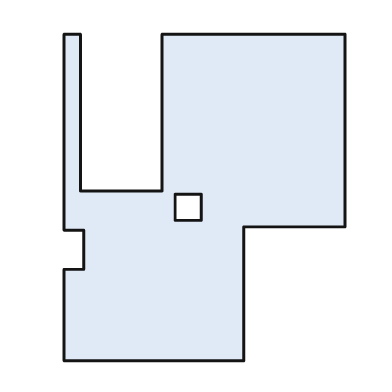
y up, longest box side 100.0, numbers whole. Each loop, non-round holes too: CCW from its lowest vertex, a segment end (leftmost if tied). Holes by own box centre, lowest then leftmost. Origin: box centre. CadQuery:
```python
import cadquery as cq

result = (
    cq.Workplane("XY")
    .moveTo(-43.0, -50.0)
    .lineTo(12.0, -50.0)
    .lineTo(12.0, -9.0)
    .lineTo(43.0, -9.0)
    .lineTo(43.0, 50.0)
    .lineTo(-13.0, 50.0)
    .lineTo(-13.0, 2.0)
    .lineTo(-38.0, 2.0)
    .lineTo(-38.0, 50.0)
    .lineTo(-43.0, 50.0)
    .lineTo(-43.0, -10.0)
    .lineTo(-37.0, -10.0)
    .lineTo(-37.0, -22.0)
    .lineTo(-43.0, -22.0)
    .close()
    .moveTo(-9.0, -7.0)
    .lineTo(-1.0, -7.0)
    .lineTo(-1.0, 1.0)
    .lineTo(-9.0, 1.0)
    .close()
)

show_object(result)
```